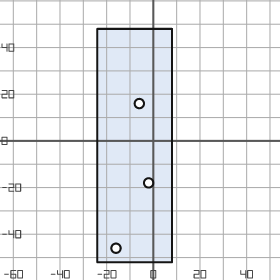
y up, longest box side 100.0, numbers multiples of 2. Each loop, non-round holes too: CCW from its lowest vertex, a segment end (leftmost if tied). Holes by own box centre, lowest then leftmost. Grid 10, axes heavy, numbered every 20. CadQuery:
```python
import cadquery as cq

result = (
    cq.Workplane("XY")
    .moveTo(-24.0, -52.0)
    .lineTo(8.0, -52.0)
    .lineTo(8.0, 48.0)
    .lineTo(-24.0, 48.0)
    .close()
    .moveTo(-16.0, -46.0)
    .circle(2.0)
    .moveTo(-2.0, -18.0)
    .circle(2.0)
    .moveTo(-6.0, 16.0)
    .circle(2.0)
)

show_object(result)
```